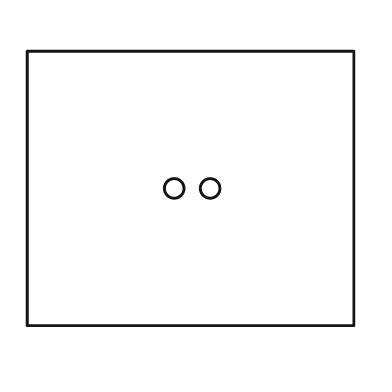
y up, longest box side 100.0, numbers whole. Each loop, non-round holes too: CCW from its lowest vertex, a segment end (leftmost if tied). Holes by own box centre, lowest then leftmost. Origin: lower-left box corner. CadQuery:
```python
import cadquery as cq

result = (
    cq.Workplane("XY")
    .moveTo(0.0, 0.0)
    .lineTo(100.0, 0.0)
    .lineTo(100.0, 84.0)
    .lineTo(0.0, 84.0)
    .close()
    .moveTo(45.0, 42.0)
    .circle(3.0)
    .moveTo(56.0, 42.0)
    .circle(3.0)
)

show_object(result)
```